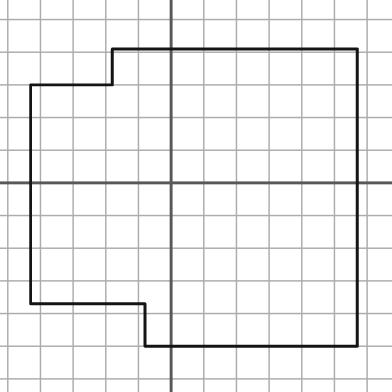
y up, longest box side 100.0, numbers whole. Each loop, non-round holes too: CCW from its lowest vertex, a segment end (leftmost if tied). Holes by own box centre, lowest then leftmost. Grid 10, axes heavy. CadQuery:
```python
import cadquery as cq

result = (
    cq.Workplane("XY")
    .moveTo(-8.0, -50.0)
    .lineTo(57.0, -50.0)
    .lineTo(57.0, 41.0)
    .lineTo(-18.0, 41.0)
    .lineTo(-18.0, 30.0)
    .lineTo(-43.0, 30.0)
    .lineTo(-43.0, -37.0)
    .lineTo(-8.0, -37.0)
    .close()
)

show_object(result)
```